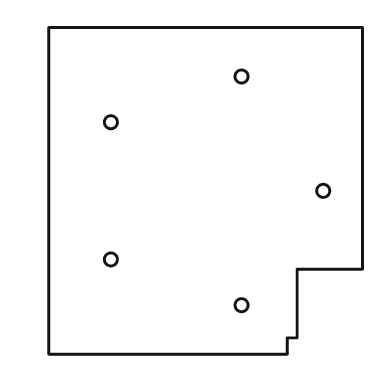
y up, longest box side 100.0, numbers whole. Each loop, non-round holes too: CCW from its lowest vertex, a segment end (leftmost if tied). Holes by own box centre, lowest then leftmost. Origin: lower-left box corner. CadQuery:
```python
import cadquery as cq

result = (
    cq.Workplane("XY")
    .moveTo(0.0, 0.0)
    .lineTo(73.0, 0.0)
    .lineTo(73.0, 5.0)
    .lineTo(76.0, 5.0)
    .lineTo(76.0, 26.0)
    .lineTo(96.0, 26.0)
    .lineTo(96.0, 100.0)
    .lineTo(0.0, 100.0)
    .close()
    .moveTo(59.0, 15.0)
    .circle(2.0)
    .moveTo(19.0, 29.0)
    .circle(2.0)
    .moveTo(84.0, 50.0)
    .circle(2.0)
    .moveTo(19.0, 71.0)
    .circle(2.0)
    .moveTo(59.0, 85.0)
    .circle(2.0)
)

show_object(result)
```